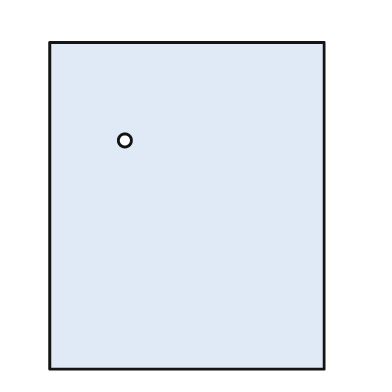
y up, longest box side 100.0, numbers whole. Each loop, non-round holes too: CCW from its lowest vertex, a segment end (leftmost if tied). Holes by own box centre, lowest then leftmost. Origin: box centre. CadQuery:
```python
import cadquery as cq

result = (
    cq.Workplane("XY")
    .moveTo(-42.0, -50.0)
    .lineTo(42.0, -50.0)
    .lineTo(42.0, 50.0)
    .lineTo(-42.0, 50.0)
    .close()
    .moveTo(-19.0, 20.0)
    .circle(2.0)
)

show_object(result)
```